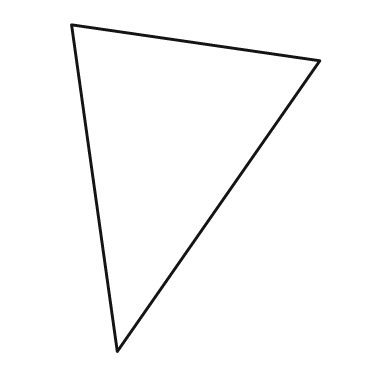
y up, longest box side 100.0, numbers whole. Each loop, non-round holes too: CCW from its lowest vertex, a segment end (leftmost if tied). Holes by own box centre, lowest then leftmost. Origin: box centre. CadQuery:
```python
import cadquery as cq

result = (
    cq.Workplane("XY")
    .moveTo(-24.0, -50.0)
    .lineTo(38.0, 39.0)
    .lineTo(-38.0, 50.0)
    .close()
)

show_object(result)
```